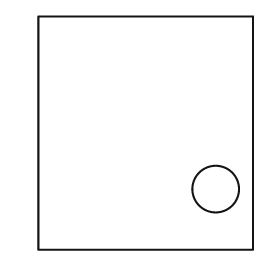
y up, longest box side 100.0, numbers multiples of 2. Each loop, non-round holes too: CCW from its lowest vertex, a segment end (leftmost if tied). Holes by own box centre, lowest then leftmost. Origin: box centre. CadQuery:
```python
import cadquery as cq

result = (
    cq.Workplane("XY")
    .moveTo(-46.0, -50.0)
    .lineTo(46.0, -50.0)
    .lineTo(46.0, 50.0)
    .lineTo(-46.0, 50.0)
    .close()
    .moveTo(30.0, -24.0)
    .circle(10.0)
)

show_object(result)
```